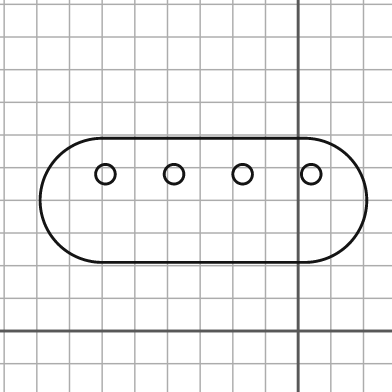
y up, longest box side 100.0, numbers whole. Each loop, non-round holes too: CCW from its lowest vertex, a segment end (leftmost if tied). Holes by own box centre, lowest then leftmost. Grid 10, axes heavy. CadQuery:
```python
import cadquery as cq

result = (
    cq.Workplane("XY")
    .moveTo(-60.0, 21.0)
    .lineTo(2.0, 21.0)
    .threePointArc((21.0, 40.0), (2.0, 59.0))
    .lineTo(-60.0, 59.0)
    .threePointArc((-79.0, 40.0), (-60.0, 21.0))
    .close()
    .moveTo(-59.0, 48.0)
    .circle(3.0)
    .moveTo(-38.0, 48.0)
    .circle(3.0)
    .moveTo(-17.0, 48.0)
    .circle(3.0)
    .moveTo(4.0, 48.0)
    .circle(3.0)
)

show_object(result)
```